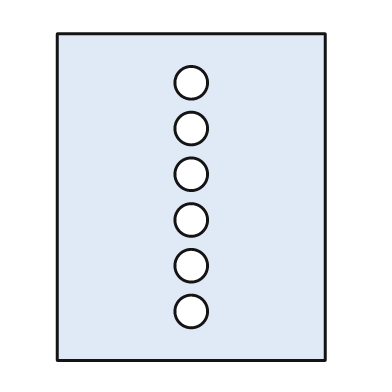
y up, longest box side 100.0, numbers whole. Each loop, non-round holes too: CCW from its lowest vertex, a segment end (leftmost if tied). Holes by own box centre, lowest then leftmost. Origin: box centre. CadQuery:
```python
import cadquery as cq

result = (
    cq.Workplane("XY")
    .moveTo(-41.0, -50.0)
    .lineTo(41.0, -50.0)
    .lineTo(41.0, 50.0)
    .lineTo(-41.0, 50.0)
    .close()
    .moveTo(0.0, -35.0)
    .circle(5.0)
    .moveTo(0.0, -21.0)
    .circle(5.0)
    .moveTo(0.0, -7.0)
    .circle(5.0)
    .moveTo(0.0, 7.0)
    .circle(5.0)
    .moveTo(0.0, 21.0)
    .circle(5.0)
    .moveTo(0.0, 35.0)
    .circle(5.0)
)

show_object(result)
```